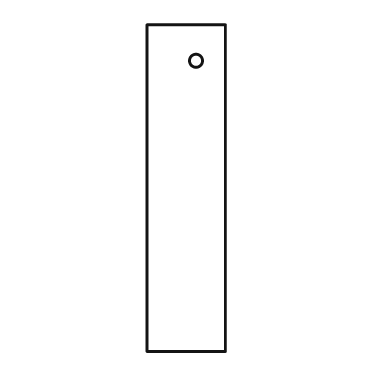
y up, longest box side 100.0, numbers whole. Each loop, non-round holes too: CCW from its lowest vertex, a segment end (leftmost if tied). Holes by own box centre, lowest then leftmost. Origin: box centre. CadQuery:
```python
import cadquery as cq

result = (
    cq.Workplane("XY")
    .moveTo(-12.0, -50.0)
    .lineTo(12.0, -50.0)
    .lineTo(12.0, 50.0)
    .lineTo(-12.0, 50.0)
    .close()
    .moveTo(3.0, 39.0)
    .circle(2.0)
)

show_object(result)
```